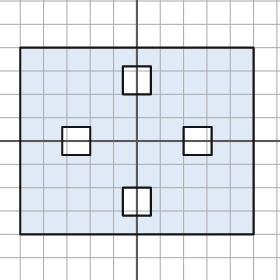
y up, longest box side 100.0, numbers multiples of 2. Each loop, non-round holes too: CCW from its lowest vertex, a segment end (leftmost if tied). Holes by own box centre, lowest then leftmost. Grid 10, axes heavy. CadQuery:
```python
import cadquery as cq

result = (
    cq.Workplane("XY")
    .moveTo(-50.0, -40.0)
    .lineTo(50.0, -40.0)
    .lineTo(50.0, 40.0)
    .lineTo(-50.0, 40.0)
    .close()
    .moveTo(-6.0, -32.0)
    .lineTo(6.0, -32.0)
    .lineTo(6.0, -20.0)
    .lineTo(-6.0, -20.0)
    .close()
    .moveTo(-32.0, -6.0)
    .lineTo(-20.0, -6.0)
    .lineTo(-20.0, 6.0)
    .lineTo(-32.0, 6.0)
    .close()
    .moveTo(20.0, -6.0)
    .lineTo(32.0, -6.0)
    .lineTo(32.0, 6.0)
    .lineTo(20.0, 6.0)
    .close()
    .moveTo(-6.0, 20.0)
    .lineTo(6.0, 20.0)
    .lineTo(6.0, 32.0)
    .lineTo(-6.0, 32.0)
    .close()
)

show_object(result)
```